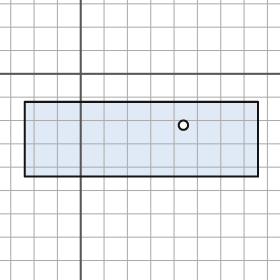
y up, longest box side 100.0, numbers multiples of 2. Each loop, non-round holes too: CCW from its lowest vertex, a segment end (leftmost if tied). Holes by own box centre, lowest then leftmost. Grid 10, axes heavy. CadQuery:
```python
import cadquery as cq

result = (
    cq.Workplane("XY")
    .moveTo(-24.0, -44.0)
    .lineTo(76.0, -44.0)
    .lineTo(76.0, -12.0)
    .lineTo(-24.0, -12.0)
    .close()
    .moveTo(44.0, -22.0)
    .circle(2.0)
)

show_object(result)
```